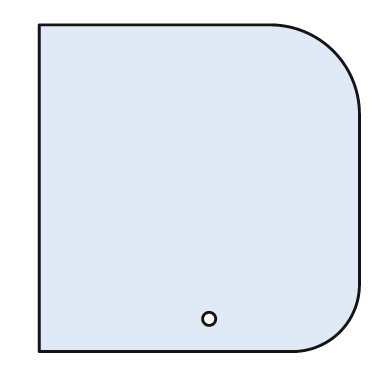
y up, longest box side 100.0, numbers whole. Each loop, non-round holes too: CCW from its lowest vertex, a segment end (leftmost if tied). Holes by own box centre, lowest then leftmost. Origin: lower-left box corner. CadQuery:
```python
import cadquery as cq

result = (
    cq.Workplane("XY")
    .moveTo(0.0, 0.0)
    .lineTo(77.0, 0.0)
    .threePointArc((92.0, 6.0), (98.0, 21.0))
    .lineTo(98.0, 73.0)
    .threePointArc((90.0, 92.0), (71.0, 100.0))
    .lineTo(0.0, 100.0)
    .close()
    .moveTo(52.0, 10.0)
    .circle(2.0)
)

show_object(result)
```